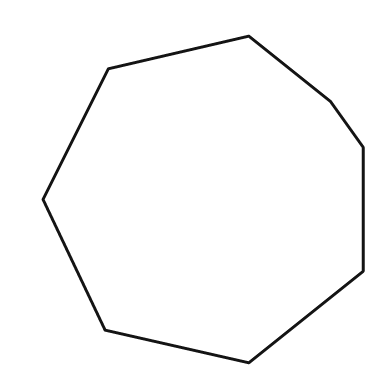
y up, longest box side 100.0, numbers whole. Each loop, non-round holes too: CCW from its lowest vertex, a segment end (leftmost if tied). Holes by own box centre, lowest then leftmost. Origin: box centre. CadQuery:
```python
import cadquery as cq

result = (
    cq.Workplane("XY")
    .moveTo(14.0, -50.0)
    .lineTo(49.0, -22.0)
    .lineTo(49.0, 16.0)
    .lineTo(39.0, 30.0)
    .lineTo(14.0, 50.0)
    .lineTo(-29.0, 40.0)
    .lineTo(-49.0, 0.0)
    .lineTo(-30.0, -40.0)
    .close()
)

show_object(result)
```